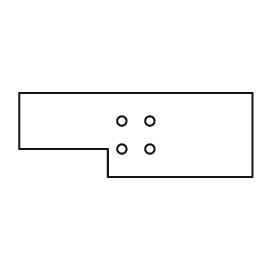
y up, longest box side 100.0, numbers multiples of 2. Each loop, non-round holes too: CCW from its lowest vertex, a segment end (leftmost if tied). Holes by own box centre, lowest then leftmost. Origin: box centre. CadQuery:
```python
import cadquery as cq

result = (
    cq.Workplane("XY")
    .moveTo(-12.0, -18.0)
    .lineTo(50.0, -18.0)
    .lineTo(50.0, 18.0)
    .lineTo(-50.0, 18.0)
    .lineTo(-50.0, -6.0)
    .lineTo(-12.0, -6.0)
    .close()
    .moveTo(-6.0, -6.0)
    .circle(2.0)
    .moveTo(6.0, -6.0)
    .circle(2.0)
    .moveTo(-6.0, 6.0)
    .circle(2.0)
    .moveTo(6.0, 6.0)
    .circle(2.0)
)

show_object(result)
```